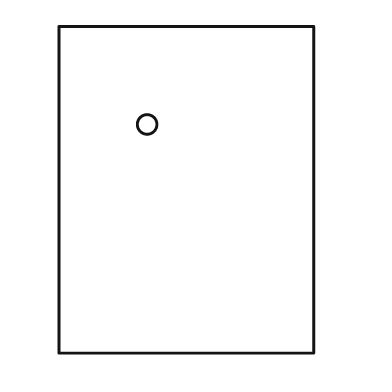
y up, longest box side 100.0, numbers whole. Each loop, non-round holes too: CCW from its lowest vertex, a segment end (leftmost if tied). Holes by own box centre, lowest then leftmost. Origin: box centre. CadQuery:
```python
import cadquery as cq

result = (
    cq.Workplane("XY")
    .moveTo(-39.0, -50.0)
    .lineTo(39.0, -50.0)
    .lineTo(39.0, 50.0)
    .lineTo(-39.0, 50.0)
    .close()
    .moveTo(-12.0, 20.0)
    .circle(3.0)
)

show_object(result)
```